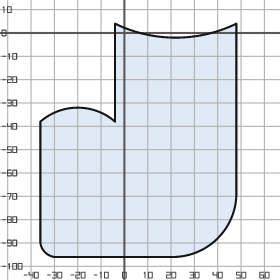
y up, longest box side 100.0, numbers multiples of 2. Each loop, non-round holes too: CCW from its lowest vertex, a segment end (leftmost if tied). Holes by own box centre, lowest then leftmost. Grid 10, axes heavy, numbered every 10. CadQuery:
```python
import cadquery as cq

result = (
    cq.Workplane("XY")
    .moveTo(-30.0, -96.0)
    .lineTo(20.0, -96.0)
    .threePointArc((40.0, -88.0), (48.0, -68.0))
    .lineTo(48.0, 4.0)
    .threePointArc((22.0, -2.0), (-4.0, 4.0))
    .lineTo(-4.0, -38.0)
    .threePointArc((-20.0, -32.0), (-36.0, -38.0))
    .lineTo(-36.0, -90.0)
    .threePointArc((-34.0, -94.0), (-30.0, -96.0))
    .close()
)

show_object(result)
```